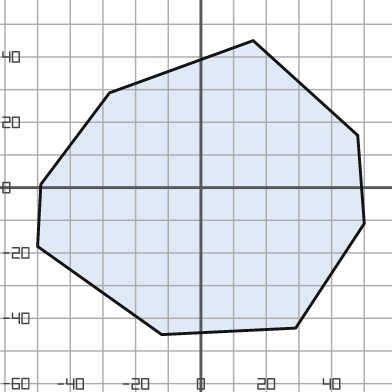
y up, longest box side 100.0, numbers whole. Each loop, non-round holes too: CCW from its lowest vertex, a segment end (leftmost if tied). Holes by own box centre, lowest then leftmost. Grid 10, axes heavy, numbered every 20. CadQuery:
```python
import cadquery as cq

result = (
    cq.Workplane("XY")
    .moveTo(-12.0, -45.0)
    .lineTo(29.0, -43.0)
    .lineTo(50.0, -11.0)
    .lineTo(48.0, 16.0)
    .lineTo(16.0, 45.0)
    .lineTo(-28.0, 29.0)
    .lineTo(-49.0, 1.0)
    .lineTo(-50.0, -18.0)
    .close()
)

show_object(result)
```